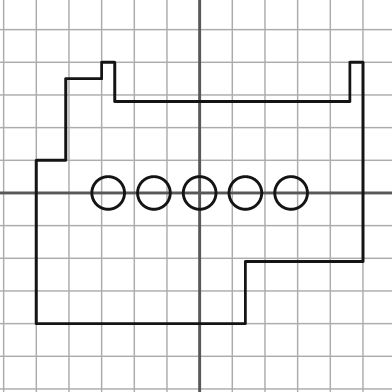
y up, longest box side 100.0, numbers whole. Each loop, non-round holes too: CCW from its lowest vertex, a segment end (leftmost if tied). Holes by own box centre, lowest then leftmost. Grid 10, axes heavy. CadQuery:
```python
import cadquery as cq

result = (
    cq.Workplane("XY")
    .moveTo(-50.0, -40.0)
    .lineTo(14.0, -40.0)
    .lineTo(14.0, -21.0)
    .lineTo(50.0, -21.0)
    .lineTo(50.0, 40.0)
    .lineTo(46.0, 40.0)
    .lineTo(46.0, 28.0)
    .lineTo(-26.0, 28.0)
    .lineTo(-26.0, 40.0)
    .lineTo(-30.0, 40.0)
    .lineTo(-30.0, 35.0)
    .lineTo(-41.0, 35.0)
    .lineTo(-41.0, 10.0)
    .lineTo(-50.0, 10.0)
    .close()
    .moveTo(-28.0, 0.0)
    .circle(5.0)
    .moveTo(-14.0, 0.0)
    .circle(5.0)
    .moveTo(0.0, 0.0)
    .circle(5.0)
    .moveTo(14.0, 0.0)
    .circle(5.0)
    .moveTo(28.0, 0.0)
    .circle(5.0)
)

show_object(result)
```